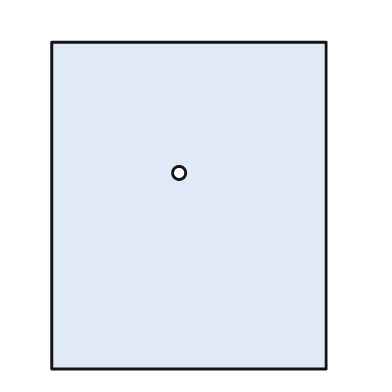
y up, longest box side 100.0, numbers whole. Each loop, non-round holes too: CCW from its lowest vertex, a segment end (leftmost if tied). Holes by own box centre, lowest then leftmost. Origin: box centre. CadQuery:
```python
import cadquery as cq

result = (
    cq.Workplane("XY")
    .moveTo(-42.0, -50.0)
    .lineTo(42.0, -50.0)
    .lineTo(42.0, 50.0)
    .lineTo(-42.0, 50.0)
    .close()
    .moveTo(-3.0, 10.0)
    .circle(2.0)
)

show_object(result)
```